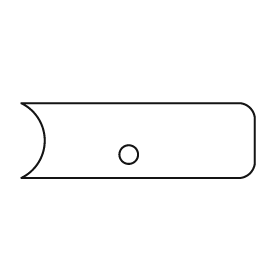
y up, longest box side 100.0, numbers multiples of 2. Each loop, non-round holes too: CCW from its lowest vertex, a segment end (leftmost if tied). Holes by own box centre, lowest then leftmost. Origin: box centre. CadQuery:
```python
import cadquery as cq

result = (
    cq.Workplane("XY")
    .moveTo(-50.0, -16.0)
    .lineTo(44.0, -16.0)
    .threePointArc((48.0, -14.0), (50.0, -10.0))
    .lineTo(50.0, 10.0)
    .threePointArc((48.0, 14.0), (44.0, 16.0))
    .lineTo(-50.0, 16.0)
    .threePointArc((-40.0, 0.0), (-50.0, -16.0))
    .close()
    .moveTo(-4.0, -6.0)
    .circle(4.0)
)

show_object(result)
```